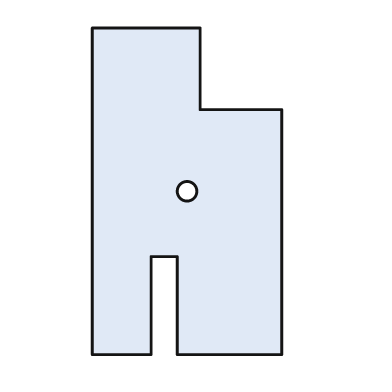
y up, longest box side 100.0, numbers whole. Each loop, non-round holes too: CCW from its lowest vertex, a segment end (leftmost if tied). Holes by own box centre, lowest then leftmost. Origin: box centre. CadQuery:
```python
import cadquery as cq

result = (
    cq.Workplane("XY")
    .moveTo(-29.0, -50.0)
    .lineTo(-11.0, -50.0)
    .lineTo(-11.0, -20.0)
    .lineTo(-3.0, -20.0)
    .lineTo(-3.0, -50.0)
    .lineTo(29.0, -50.0)
    .lineTo(29.0, 25.0)
    .lineTo(4.0, 25.0)
    .lineTo(4.0, 50.0)
    .lineTo(-29.0, 50.0)
    .close()
    .moveTo(0.0, 0.0)
    .circle(3.0)
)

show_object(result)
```